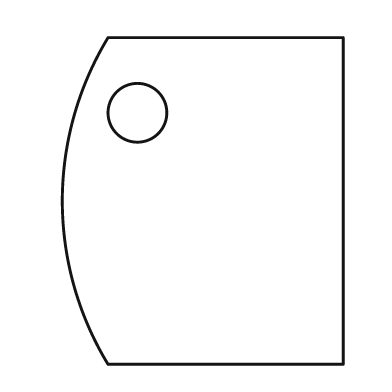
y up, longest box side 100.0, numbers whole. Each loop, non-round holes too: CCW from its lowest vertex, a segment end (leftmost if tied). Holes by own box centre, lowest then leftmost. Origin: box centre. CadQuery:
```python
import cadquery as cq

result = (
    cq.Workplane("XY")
    .moveTo(-29.0, -50.0)
    .lineTo(43.0, -50.0)
    .lineTo(43.0, 50.0)
    .lineTo(-29.0, 50.0)
    .threePointArc((-43.0, 0.0), (-29.0, -50.0))
    .close()
    .moveTo(-20.0, 27.0)
    .circle(9.0)
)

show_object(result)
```